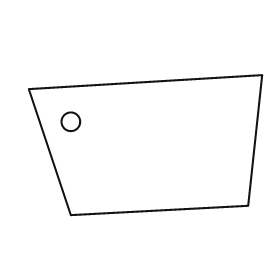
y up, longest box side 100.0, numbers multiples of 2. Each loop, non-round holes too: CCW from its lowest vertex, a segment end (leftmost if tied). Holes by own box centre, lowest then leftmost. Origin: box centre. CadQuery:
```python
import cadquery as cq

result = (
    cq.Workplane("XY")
    .moveTo(-32.0, -30.0)
    .lineTo(44.0, -26.0)
    .lineTo(50.0, 30.0)
    .lineTo(-50.0, 24.0)
    .close()
    .moveTo(-32.0, 10.0)
    .circle(4.0)
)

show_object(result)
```